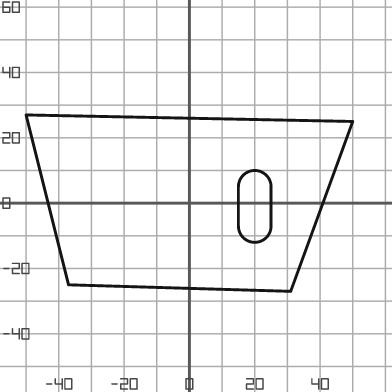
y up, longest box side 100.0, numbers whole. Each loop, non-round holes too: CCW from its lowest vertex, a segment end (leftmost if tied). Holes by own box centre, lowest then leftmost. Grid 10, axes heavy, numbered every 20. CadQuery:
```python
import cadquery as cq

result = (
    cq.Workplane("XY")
    .moveTo(31.0, -27.0)
    .lineTo(50.0, 25.0)
    .lineTo(-50.0, 27.0)
    .lineTo(-37.0, -25.0)
    .close()
    .moveTo(15.0, -7.0)
    .threePointArc((20.0, -12.0), (25.0, -7.0))
    .lineTo(25.0, 5.0)
    .threePointArc((20.0, 10.0), (15.0, 5.0))
    .close()
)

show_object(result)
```